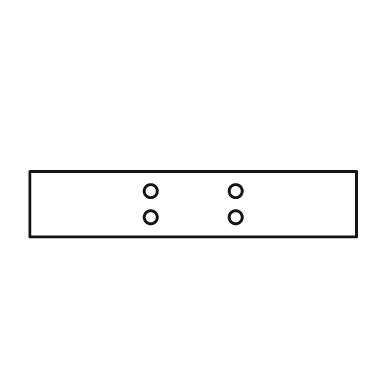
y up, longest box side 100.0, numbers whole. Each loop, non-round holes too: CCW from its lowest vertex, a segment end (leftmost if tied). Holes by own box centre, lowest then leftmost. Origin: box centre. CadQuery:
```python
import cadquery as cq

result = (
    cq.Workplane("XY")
    .moveTo(-50.0, -10.0)
    .lineTo(50.0, -10.0)
    .lineTo(50.0, 10.0)
    .lineTo(-50.0, 10.0)
    .close()
    .moveTo(-13.0, -4.0)
    .circle(2.0)
    .moveTo(13.0, -4.0)
    .circle(2.0)
    .moveTo(-13.0, 4.0)
    .circle(2.0)
    .moveTo(13.0, 4.0)
    .circle(2.0)
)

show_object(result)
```